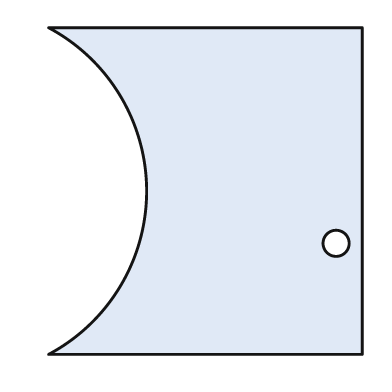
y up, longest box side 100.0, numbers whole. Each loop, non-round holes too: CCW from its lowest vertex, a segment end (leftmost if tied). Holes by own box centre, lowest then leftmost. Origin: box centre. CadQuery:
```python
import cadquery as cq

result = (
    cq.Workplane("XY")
    .moveTo(-48.0, -50.0)
    .lineTo(48.0, -50.0)
    .lineTo(48.0, 50.0)
    .lineTo(-48.0, 50.0)
    .threePointArc((-18.0, 0.0), (-48.0, -50.0))
    .close()
    .moveTo(40.0, -16.0)
    .circle(4.0)
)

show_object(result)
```